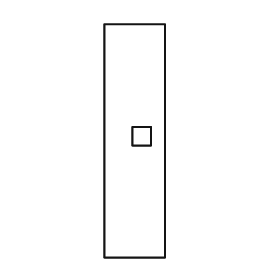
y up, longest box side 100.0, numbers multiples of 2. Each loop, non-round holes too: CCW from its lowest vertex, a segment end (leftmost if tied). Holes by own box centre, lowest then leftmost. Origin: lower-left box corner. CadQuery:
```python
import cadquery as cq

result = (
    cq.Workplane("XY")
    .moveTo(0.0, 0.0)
    .lineTo(26.0, 0.0)
    .lineTo(26.0, 100.0)
    .lineTo(0.0, 100.0)
    .close()
    .moveTo(12.0, 48.0)
    .lineTo(20.0, 48.0)
    .lineTo(20.0, 56.0)
    .lineTo(12.0, 56.0)
    .close()
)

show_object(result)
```